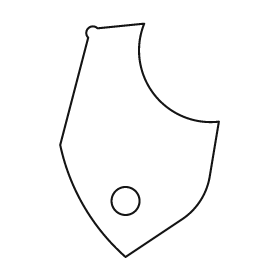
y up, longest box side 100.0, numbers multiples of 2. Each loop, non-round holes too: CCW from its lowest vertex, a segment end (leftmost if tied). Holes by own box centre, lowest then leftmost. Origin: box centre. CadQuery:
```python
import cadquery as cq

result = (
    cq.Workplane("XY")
    .moveTo(-6.0, -50.0)
    .lineTo(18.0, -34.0)
    .threePointArc((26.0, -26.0), (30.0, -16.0))
    .lineTo(34.0, 8.0)
    .threePointArc((6.0, 20.0), (2.0, 50.0))
    .lineTo(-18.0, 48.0)
    .threePointArc((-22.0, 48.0), (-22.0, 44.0))
    .lineTo(-34.0, -2.0)
    .threePointArc((-24.0, -28.0), (-6.0, -50.0))
    .close()
    .moveTo(-6.0, -26.0)
    .circle(6.0)
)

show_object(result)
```